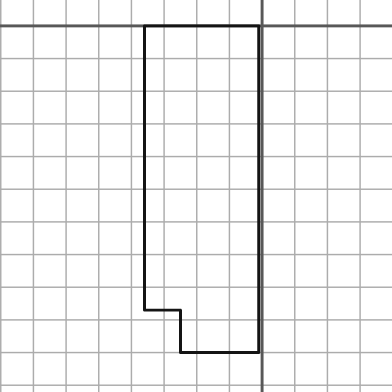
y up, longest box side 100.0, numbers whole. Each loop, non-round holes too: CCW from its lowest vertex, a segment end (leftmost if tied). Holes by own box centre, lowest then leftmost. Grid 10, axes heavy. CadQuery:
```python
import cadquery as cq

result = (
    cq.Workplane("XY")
    .moveTo(-25.0, -100.0)
    .lineTo(-1.0, -100.0)
    .lineTo(-1.0, 0.0)
    .lineTo(-36.0, 0.0)
    .lineTo(-36.0, -87.0)
    .lineTo(-25.0, -87.0)
    .close()
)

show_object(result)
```